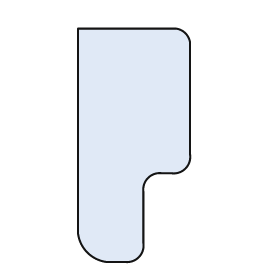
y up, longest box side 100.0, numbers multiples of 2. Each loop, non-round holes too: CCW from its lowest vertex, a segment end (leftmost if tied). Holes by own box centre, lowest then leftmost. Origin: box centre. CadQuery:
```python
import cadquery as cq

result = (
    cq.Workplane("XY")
    .moveTo(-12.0, -50.0)
    .lineTo(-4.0, -50.0)
    .threePointArc((2.0, -48.0), (4.0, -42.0))
    .lineTo(4.0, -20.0)
    .threePointArc((6.0, -14.0), (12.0, -12.0))
    .lineTo(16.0, -12.0)
    .threePointArc((22.0, -10.0), (24.0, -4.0))
    .lineTo(24.0, 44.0)
    .threePointArc((22.0, 48.0), (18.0, 50.0))
    .lineTo(-24.0, 50.0)
    .lineTo(-24.0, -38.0)
    .threePointArc((-20.0, -46.0), (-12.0, -50.0))
    .close()
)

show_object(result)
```